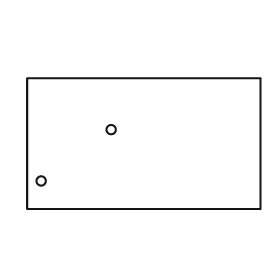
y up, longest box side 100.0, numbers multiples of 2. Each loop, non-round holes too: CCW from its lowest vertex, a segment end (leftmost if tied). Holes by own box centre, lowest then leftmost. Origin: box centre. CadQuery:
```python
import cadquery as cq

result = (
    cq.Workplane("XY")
    .moveTo(-50.0, -28.0)
    .lineTo(50.0, -28.0)
    .lineTo(50.0, 28.0)
    .lineTo(-50.0, 28.0)
    .close()
    .moveTo(-44.0, -16.0)
    .circle(2.0)
    .moveTo(-14.0, 6.0)
    .circle(2.0)
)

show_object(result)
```